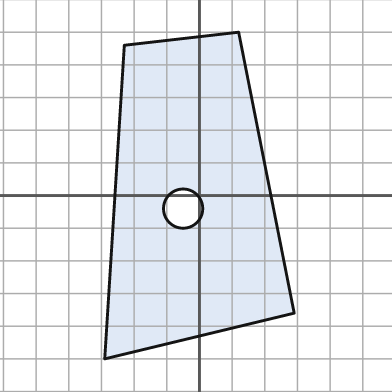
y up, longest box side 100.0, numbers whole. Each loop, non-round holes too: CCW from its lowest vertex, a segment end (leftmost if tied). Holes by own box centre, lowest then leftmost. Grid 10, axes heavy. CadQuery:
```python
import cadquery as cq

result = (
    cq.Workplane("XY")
    .moveTo(-29.0, -50.0)
    .lineTo(29.0, -36.0)
    .lineTo(12.0, 50.0)
    .lineTo(-23.0, 46.0)
    .close()
    .moveTo(-5.0, -4.0)
    .circle(6.0)
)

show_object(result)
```